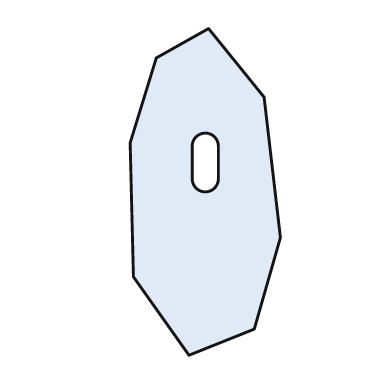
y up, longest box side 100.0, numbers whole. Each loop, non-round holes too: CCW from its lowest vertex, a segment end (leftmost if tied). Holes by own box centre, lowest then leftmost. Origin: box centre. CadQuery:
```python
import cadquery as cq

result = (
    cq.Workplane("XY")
    .moveTo(-5.0, -50.0)
    .lineTo(15.0, -42.0)
    .lineTo(23.0, -14.0)
    .lineTo(18.0, 29.0)
    .lineTo(1.0, 50.0)
    .lineTo(-15.0, 41.0)
    .lineTo(-23.0, 15.0)
    .lineTo(-22.0, -26.0)
    .close()
    .moveTo(-4.0, 4.0)
    .threePointArc((0.0, 0.0), (4.0, 4.0))
    .lineTo(4.0, 14.0)
    .threePointArc((0.0, 18.0), (-4.0, 14.0))
    .close()
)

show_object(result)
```